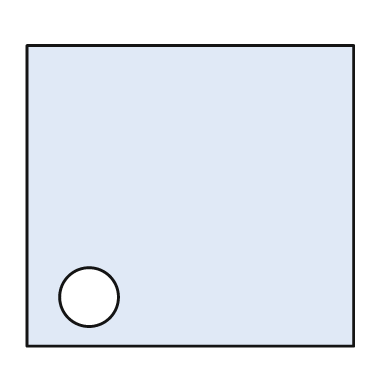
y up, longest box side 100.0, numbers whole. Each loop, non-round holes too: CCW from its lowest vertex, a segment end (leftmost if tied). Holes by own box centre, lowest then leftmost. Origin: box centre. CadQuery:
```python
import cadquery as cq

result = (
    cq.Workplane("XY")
    .moveTo(-50.0, -46.0)
    .lineTo(50.0, -46.0)
    .lineTo(50.0, 46.0)
    .lineTo(-50.0, 46.0)
    .close()
    .moveTo(-31.0, -31.0)
    .circle(9.0)
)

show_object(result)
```